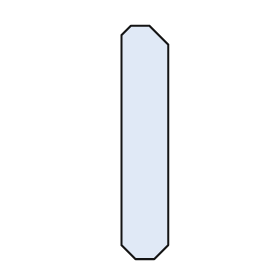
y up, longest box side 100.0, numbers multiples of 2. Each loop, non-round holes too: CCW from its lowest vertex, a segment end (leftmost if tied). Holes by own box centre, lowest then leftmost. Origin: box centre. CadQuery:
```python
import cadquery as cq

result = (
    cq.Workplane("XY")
    .moveTo(-4.0, -50.0)
    .lineTo(4.0, -50.0)
    .lineTo(10.0, -44.0)
    .lineTo(10.0, 42.0)
    .lineTo(2.0, 50.0)
    .lineTo(-6.0, 50.0)
    .lineTo(-10.0, 46.0)
    .lineTo(-10.0, -44.0)
    .close()
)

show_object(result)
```